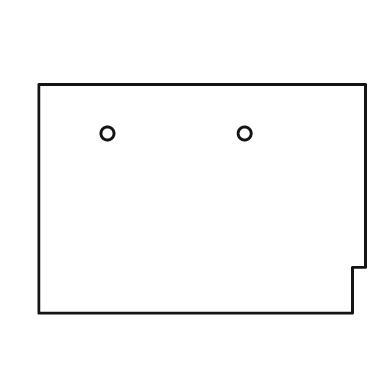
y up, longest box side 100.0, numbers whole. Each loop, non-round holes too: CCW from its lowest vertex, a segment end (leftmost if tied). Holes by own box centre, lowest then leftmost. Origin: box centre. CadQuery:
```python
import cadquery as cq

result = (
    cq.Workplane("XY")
    .moveTo(-50.0, -35.0)
    .lineTo(46.0, -35.0)
    .lineTo(46.0, -21.0)
    .lineTo(50.0, -21.0)
    .lineTo(50.0, 35.0)
    .lineTo(-50.0, 35.0)
    .close()
    .moveTo(-29.0, 20.0)
    .circle(2.0)
    .moveTo(13.0, 20.0)
    .circle(2.0)
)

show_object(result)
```